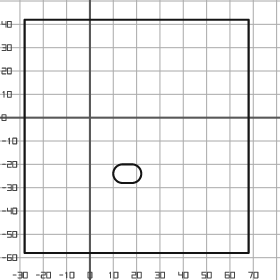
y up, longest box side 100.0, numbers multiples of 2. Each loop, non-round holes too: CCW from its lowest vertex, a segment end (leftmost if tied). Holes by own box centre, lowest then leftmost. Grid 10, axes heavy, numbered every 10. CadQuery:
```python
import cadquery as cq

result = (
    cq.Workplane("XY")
    .moveTo(-28.0, -58.0)
    .lineTo(68.0, -58.0)
    .lineTo(68.0, 42.0)
    .lineTo(-28.0, 42.0)
    .close()
    .moveTo(14.0, -28.0)
    .lineTo(18.0, -28.0)
    .threePointArc((22.0, -24.0), (18.0, -20.0))
    .lineTo(14.0, -20.0)
    .threePointArc((10.0, -24.0), (14.0, -28.0))
    .close()
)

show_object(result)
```